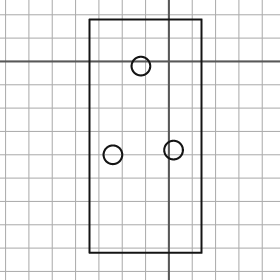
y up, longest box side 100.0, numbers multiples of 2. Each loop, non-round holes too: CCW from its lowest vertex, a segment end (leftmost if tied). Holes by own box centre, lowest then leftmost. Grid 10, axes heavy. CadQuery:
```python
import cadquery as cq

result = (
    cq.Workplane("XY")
    .moveTo(-34.0, -82.0)
    .lineTo(14.0, -82.0)
    .lineTo(14.0, 18.0)
    .lineTo(-34.0, 18.0)
    .close()
    .moveTo(-24.0, -40.0)
    .circle(4.0)
    .moveTo(2.0, -38.0)
    .circle(4.0)
    .moveTo(-12.0, -2.0)
    .circle(4.0)
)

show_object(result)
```